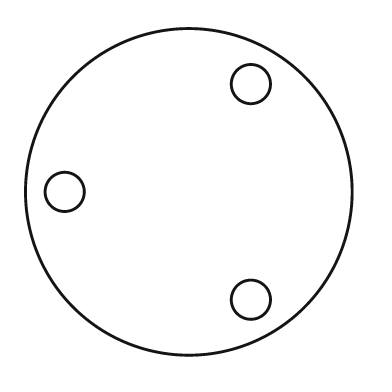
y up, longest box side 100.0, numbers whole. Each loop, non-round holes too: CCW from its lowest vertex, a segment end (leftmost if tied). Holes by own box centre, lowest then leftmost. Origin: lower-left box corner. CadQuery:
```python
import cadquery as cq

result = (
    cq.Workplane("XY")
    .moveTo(50.0, 50.0)
    .circle(50.0)
    .moveTo(69.0, 17.0)
    .circle(6.0)
    .moveTo(12.0, 50.0)
    .circle(6.0)
    .moveTo(69.0, 83.0)
    .circle(6.0)
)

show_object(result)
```